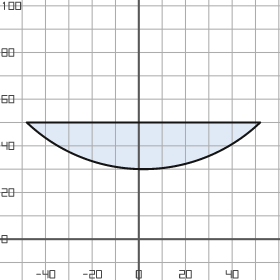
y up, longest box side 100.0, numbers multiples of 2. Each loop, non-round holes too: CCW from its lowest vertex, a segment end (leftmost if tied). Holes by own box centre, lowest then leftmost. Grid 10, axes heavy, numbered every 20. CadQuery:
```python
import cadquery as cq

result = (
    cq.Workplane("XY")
    .moveTo(-48.0, 50.0)
    .threePointArc((2.0, 30.0), (52.0, 50.0))
    .close()
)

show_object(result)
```